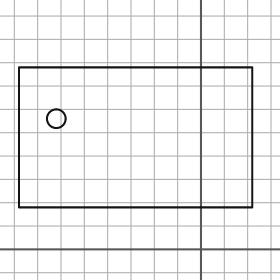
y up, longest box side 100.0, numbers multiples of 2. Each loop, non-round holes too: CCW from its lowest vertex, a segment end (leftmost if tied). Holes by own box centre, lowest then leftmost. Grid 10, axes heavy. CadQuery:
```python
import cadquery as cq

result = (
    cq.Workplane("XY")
    .moveTo(-78.0, 18.0)
    .lineTo(22.0, 18.0)
    .lineTo(22.0, 78.0)
    .lineTo(-78.0, 78.0)
    .close()
    .moveTo(-62.0, 56.0)
    .circle(4.0)
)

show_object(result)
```